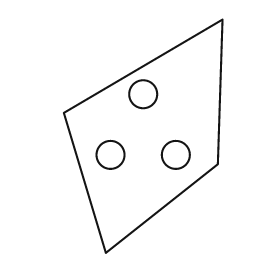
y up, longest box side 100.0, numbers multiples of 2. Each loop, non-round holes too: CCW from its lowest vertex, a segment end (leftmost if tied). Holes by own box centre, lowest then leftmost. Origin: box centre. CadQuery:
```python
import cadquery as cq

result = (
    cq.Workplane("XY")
    .moveTo(-16.0, -50.0)
    .lineTo(32.0, -12.0)
    .lineTo(34.0, 50.0)
    .lineTo(-34.0, 10.0)
    .close()
    .moveTo(-14.0, -8.0)
    .circle(6.0)
    .moveTo(14.0, -8.0)
    .circle(6.0)
    .moveTo(0.0, 18.0)
    .circle(6.0)
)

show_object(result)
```